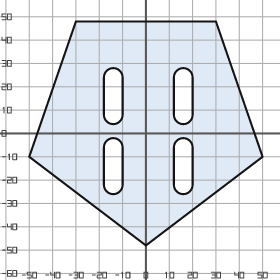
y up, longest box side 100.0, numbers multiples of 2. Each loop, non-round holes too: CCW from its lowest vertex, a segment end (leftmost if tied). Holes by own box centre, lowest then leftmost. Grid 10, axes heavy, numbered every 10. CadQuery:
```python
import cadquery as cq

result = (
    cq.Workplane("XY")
    .moveTo(0.0, -48.0)
    .lineTo(50.0, -10.0)
    .lineTo(30.0, 48.0)
    .lineTo(-30.0, 48.0)
    .lineTo(-50.0, -10.0)
    .close()
    .moveTo(-18.0, -22.0)
    .threePointArc((-14.0, -26.0), (-10.0, -22.0))
    .lineTo(-10.0, -6.0)
    .threePointArc((-14.0, -2.0), (-18.0, -6.0))
    .close()
    .moveTo(12.0, -22.0)
    .threePointArc((16.0, -26.0), (20.0, -22.0))
    .lineTo(20.0, -6.0)
    .threePointArc((16.0, -2.0), (12.0, -6.0))
    .close()
    .moveTo(-18.0, 8.0)
    .threePointArc((-14.0, 4.0), (-10.0, 8.0))
    .lineTo(-10.0, 24.0)
    .threePointArc((-14.0, 28.0), (-18.0, 24.0))
    .close()
    .moveTo(12.0, 8.0)
    .threePointArc((16.0, 4.0), (20.0, 8.0))
    .lineTo(20.0, 24.0)
    .threePointArc((16.0, 28.0), (12.0, 24.0))
    .close()
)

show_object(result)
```